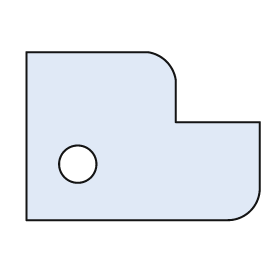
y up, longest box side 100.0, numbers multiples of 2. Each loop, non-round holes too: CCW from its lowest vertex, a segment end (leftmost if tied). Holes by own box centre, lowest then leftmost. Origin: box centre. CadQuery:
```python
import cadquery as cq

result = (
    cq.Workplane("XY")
    .moveTo(-50.0, -36.0)
    .lineTo(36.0, -36.0)
    .threePointArc((46.0, -32.0), (50.0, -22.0))
    .lineTo(50.0, 6.0)
    .lineTo(14.0, 6.0)
    .lineTo(14.0, 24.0)
    .threePointArc((10.0, 32.0), (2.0, 36.0))
    .lineTo(-50.0, 36.0)
    .close()
    .moveTo(-28.0, -12.0)
    .circle(8.0)
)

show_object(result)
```